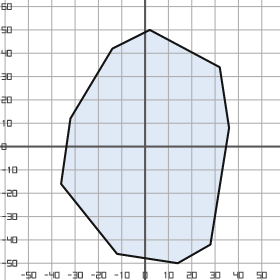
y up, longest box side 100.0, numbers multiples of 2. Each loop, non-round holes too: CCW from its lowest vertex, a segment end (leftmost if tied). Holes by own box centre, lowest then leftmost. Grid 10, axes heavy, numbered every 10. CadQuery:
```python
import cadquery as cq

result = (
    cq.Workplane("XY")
    .moveTo(14.0, -50.0)
    .lineTo(28.0, -42.0)
    .lineTo(36.0, 8.0)
    .lineTo(32.0, 34.0)
    .lineTo(2.0, 50.0)
    .lineTo(-14.0, 42.0)
    .lineTo(-32.0, 12.0)
    .lineTo(-36.0, -16.0)
    .lineTo(-12.0, -46.0)
    .close()
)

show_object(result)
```